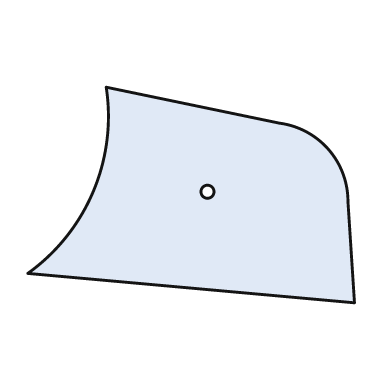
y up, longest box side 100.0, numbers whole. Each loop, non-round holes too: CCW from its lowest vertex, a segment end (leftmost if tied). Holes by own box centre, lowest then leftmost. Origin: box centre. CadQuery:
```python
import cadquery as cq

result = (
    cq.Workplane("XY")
    .moveTo(50.0, -33.0)
    .lineTo(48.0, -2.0)
    .threePointArc((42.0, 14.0), (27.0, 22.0))
    .lineTo(-26.0, 33.0)
    .threePointArc((-30.0, 1.0), (-50.0, -24.0))
    .close()
    .moveTo(5.0, 1.0)
    .circle(2.0)
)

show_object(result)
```